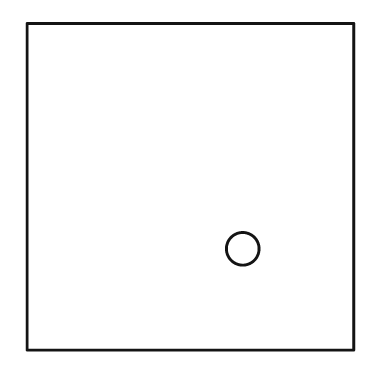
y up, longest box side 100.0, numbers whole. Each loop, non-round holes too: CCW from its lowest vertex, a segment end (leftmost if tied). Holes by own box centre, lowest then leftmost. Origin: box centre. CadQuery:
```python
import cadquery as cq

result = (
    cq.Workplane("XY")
    .moveTo(-50.0, -50.0)
    .lineTo(50.0, -50.0)
    .lineTo(50.0, 50.0)
    .lineTo(-50.0, 50.0)
    .close()
    .moveTo(16.0, -19.0)
    .circle(5.0)
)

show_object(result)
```